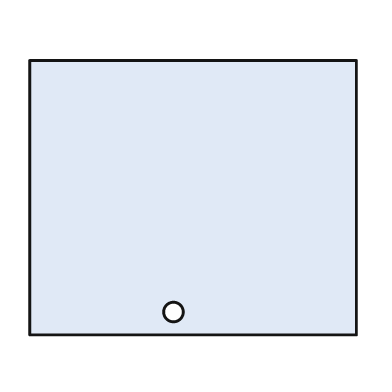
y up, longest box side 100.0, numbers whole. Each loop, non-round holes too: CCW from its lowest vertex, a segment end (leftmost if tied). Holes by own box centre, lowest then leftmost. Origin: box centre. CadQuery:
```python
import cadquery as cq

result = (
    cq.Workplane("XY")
    .moveTo(-50.0, -42.0)
    .lineTo(50.0, -42.0)
    .lineTo(50.0, 42.0)
    .lineTo(-50.0, 42.0)
    .close()
    .moveTo(-6.0, -35.0)
    .circle(3.0)
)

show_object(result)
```